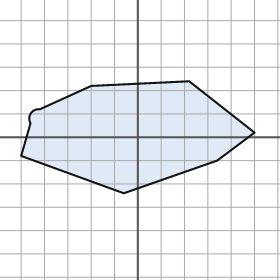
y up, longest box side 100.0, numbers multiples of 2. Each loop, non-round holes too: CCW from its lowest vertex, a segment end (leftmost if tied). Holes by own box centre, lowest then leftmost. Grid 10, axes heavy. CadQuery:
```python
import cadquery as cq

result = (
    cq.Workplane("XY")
    .moveTo(-6.0, -24.0)
    .lineTo(34.0, -10.0)
    .lineTo(50.0, 2.0)
    .lineTo(22.0, 24.0)
    .lineTo(-20.0, 22.0)
    .lineTo(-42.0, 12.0)
    .threePointArc((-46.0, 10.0), (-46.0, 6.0))
    .lineTo(-50.0, -8.0)
    .close()
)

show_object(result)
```